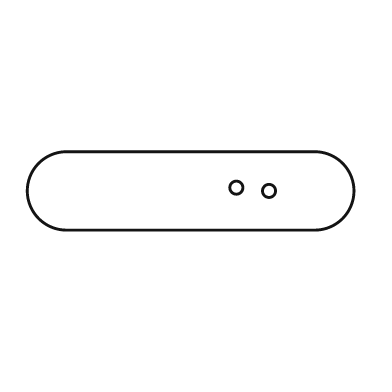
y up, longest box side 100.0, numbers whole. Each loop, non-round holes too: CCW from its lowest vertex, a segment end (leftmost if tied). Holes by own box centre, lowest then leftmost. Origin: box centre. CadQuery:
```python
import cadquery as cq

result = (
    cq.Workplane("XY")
    .moveTo(-38.0, -12.0)
    .lineTo(38.0, -12.0)
    .threePointArc((50.0, 0.0), (38.0, 12.0))
    .lineTo(-38.0, 12.0)
    .threePointArc((-50.0, 0.0), (-38.0, -12.0))
    .close()
    .moveTo(24.0, 0.0)
    .circle(2.0)
    .moveTo(14.0, 1.0)
    .circle(2.0)
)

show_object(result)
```